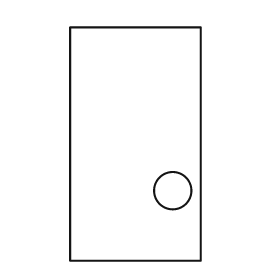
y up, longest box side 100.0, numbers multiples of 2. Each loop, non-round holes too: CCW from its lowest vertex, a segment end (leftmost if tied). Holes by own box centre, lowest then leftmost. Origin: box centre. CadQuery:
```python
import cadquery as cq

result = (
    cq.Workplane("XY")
    .moveTo(-28.0, -50.0)
    .lineTo(28.0, -50.0)
    .lineTo(28.0, 50.0)
    .lineTo(-28.0, 50.0)
    .close()
    .moveTo(16.0, -20.0)
    .circle(8.0)
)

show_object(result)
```